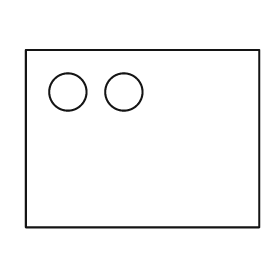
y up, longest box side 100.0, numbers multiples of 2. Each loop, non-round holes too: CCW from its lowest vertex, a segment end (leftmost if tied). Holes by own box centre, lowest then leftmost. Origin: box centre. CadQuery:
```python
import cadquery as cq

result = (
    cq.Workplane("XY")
    .moveTo(-50.0, -38.0)
    .lineTo(50.0, -38.0)
    .lineTo(50.0, 38.0)
    .lineTo(-50.0, 38.0)
    .close()
    .moveTo(-32.0, 20.0)
    .circle(8.0)
    .moveTo(-8.0, 20.0)
    .circle(8.0)
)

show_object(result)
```